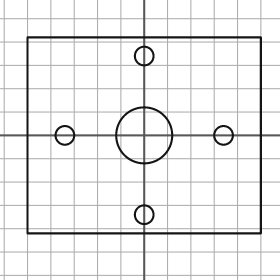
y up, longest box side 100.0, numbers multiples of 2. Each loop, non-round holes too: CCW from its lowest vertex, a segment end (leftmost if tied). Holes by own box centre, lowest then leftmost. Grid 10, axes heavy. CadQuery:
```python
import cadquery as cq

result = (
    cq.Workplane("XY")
    .moveTo(-50.0, -42.0)
    .lineTo(50.0, -42.0)
    .lineTo(50.0, 42.0)
    .lineTo(-50.0, 42.0)
    .close()
    .moveTo(0.0, -34.0)
    .circle(4.0)
    .moveTo(-34.0, 0.0)
    .circle(4.0)
    .moveTo(0.0, 0.0)
    .circle(12.0)
    .moveTo(34.0, 0.0)
    .circle(4.0)
    .moveTo(0.0, 34.0)
    .circle(4.0)
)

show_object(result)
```